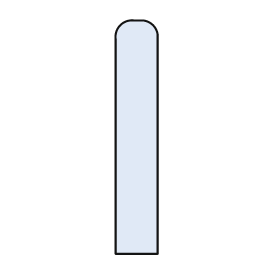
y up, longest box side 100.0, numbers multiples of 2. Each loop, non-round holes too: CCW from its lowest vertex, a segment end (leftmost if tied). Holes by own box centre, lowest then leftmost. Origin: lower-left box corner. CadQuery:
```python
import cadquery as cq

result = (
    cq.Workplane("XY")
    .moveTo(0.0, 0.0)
    .lineTo(18.0, 0.0)
    .lineTo(18.0, 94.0)
    .threePointArc((16.0, 98.0), (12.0, 100.0))
    .lineTo(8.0, 100.0)
    .threePointArc((2.0, 98.0), (0.0, 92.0))
    .close()
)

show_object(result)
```